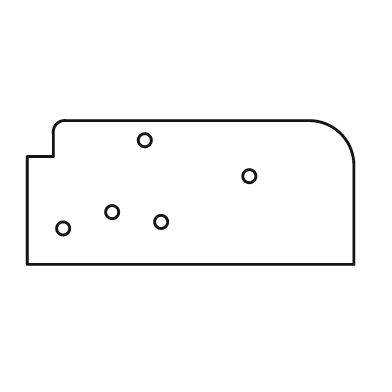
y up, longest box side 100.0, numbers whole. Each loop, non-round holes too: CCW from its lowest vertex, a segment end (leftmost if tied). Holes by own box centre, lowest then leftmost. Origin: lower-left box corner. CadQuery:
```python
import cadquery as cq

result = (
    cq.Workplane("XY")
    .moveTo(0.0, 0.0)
    .lineTo(100.0, 0.0)
    .lineTo(100.0, 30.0)
    .threePointArc((96.0, 40.0), (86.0, 44.0))
    .lineTo(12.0, 44.0)
    .threePointArc((9.0, 43.0), (8.0, 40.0))
    .lineTo(8.0, 33.0)
    .lineTo(0.0, 33.0)
    .close()
    .moveTo(11.0, 11.0)
    .circle(2.0)
    .moveTo(41.0, 13.0)
    .circle(2.0)
    .moveTo(26.0, 16.0)
    .circle(2.0)
    .moveTo(68.0, 27.0)
    .circle(2.0)
    .moveTo(36.0, 38.0)
    .circle(2.0)
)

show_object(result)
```